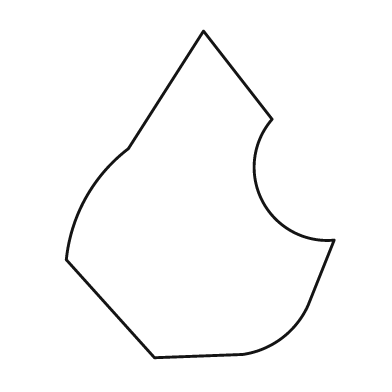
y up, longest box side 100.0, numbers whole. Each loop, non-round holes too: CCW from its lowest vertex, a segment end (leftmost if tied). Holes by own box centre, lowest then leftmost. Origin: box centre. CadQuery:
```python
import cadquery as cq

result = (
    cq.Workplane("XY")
    .moveTo(-14.0, -50.0)
    .lineTo(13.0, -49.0)
    .threePointArc((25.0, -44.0), (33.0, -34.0))
    .lineTo(41.0, -14.0)
    .threePointArc((19.0, -2.0), (22.0, 23.0))
    .lineTo(1.0, 50.0)
    .lineTo(-22.0, 14.0)
    .threePointArc((-35.0, -1.0), (-41.0, -20.0))
    .close()
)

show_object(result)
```